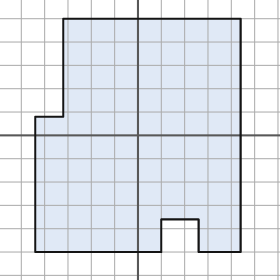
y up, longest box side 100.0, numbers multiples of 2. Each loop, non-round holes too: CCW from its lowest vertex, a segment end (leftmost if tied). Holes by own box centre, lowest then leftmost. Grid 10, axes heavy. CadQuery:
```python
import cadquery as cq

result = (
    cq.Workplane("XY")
    .moveTo(-44.0, -50.0)
    .lineTo(10.0, -50.0)
    .lineTo(10.0, -36.0)
    .lineTo(26.0, -36.0)
    .lineTo(26.0, -50.0)
    .lineTo(44.0, -50.0)
    .lineTo(44.0, 50.0)
    .lineTo(-32.0, 50.0)
    .lineTo(-32.0, 8.0)
    .lineTo(-44.0, 8.0)
    .close()
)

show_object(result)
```